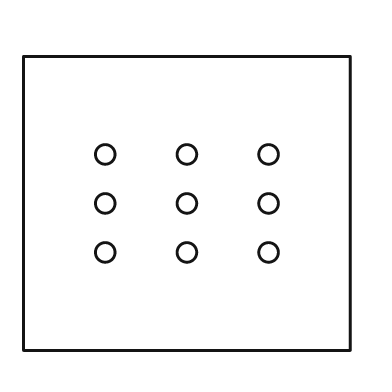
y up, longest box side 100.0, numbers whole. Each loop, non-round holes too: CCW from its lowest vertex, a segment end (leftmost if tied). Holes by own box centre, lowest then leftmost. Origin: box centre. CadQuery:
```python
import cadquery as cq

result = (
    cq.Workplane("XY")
    .moveTo(-50.0, -45.0)
    .lineTo(50.0, -45.0)
    .lineTo(50.0, 45.0)
    .lineTo(-50.0, 45.0)
    .close()
    .moveTo(-25.0, -15.0)
    .circle(3.0)
    .moveTo(0.0, -15.0)
    .circle(3.0)
    .moveTo(25.0, -15.0)
    .circle(3.0)
    .moveTo(-25.0, 0.0)
    .circle(3.0)
    .moveTo(0.0, 0.0)
    .circle(3.0)
    .moveTo(25.0, 0.0)
    .circle(3.0)
    .moveTo(-25.0, 15.0)
    .circle(3.0)
    .moveTo(0.0, 15.0)
    .circle(3.0)
    .moveTo(25.0, 15.0)
    .circle(3.0)
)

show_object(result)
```